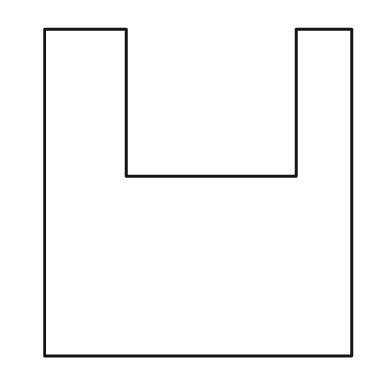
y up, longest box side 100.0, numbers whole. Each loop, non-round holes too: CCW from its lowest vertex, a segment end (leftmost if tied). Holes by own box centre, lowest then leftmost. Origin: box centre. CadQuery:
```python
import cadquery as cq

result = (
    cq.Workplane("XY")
    .moveTo(-47.0, -50.0)
    .lineTo(47.0, -50.0)
    .lineTo(47.0, 50.0)
    .lineTo(30.0, 50.0)
    .lineTo(30.0, 5.0)
    .lineTo(-22.0, 5.0)
    .lineTo(-22.0, 50.0)
    .lineTo(-47.0, 50.0)
    .close()
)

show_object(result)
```